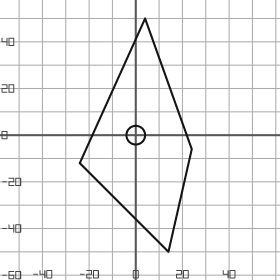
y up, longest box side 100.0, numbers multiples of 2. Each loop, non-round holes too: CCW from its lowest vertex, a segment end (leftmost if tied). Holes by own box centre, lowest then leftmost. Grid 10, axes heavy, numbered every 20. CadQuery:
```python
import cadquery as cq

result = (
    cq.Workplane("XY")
    .moveTo(14.0, -50.0)
    .lineTo(24.0, -6.0)
    .lineTo(4.0, 50.0)
    .lineTo(-24.0, -12.0)
    .close()
    .moveTo(0.0, 0.0)
    .circle(4.0)
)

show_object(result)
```